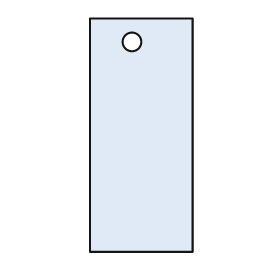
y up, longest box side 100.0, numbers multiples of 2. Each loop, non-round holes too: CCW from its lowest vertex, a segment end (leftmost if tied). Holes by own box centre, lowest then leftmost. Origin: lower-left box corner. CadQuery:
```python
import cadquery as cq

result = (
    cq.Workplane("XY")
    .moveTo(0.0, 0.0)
    .lineTo(44.0, 0.0)
    .lineTo(44.0, 100.0)
    .lineTo(0.0, 100.0)
    .close()
    .moveTo(18.0, 90.0)
    .circle(4.0)
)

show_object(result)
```